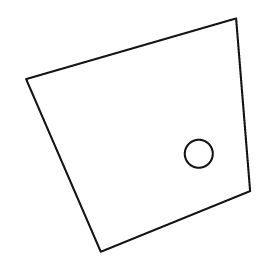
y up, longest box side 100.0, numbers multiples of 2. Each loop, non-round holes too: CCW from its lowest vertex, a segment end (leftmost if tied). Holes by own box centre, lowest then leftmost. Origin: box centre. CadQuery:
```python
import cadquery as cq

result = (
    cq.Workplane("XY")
    .moveTo(-16.0, -50.0)
    .lineTo(48.0, -24.0)
    .lineTo(42.0, 50.0)
    .lineTo(-48.0, 24.0)
    .close()
    .moveTo(26.0, -8.0)
    .circle(6.0)
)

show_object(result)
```